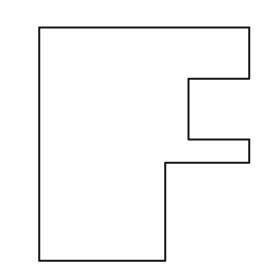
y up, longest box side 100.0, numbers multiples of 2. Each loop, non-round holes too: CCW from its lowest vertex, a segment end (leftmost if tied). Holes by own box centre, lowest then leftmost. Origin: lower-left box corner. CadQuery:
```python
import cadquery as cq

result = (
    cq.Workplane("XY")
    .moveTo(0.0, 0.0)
    .lineTo(54.0, 0.0)
    .lineTo(54.0, 42.0)
    .lineTo(90.0, 42.0)
    .lineTo(90.0, 52.0)
    .lineTo(64.0, 52.0)
    .lineTo(64.0, 78.0)
    .lineTo(90.0, 78.0)
    .lineTo(90.0, 100.0)
    .lineTo(0.0, 100.0)
    .close()
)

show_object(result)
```